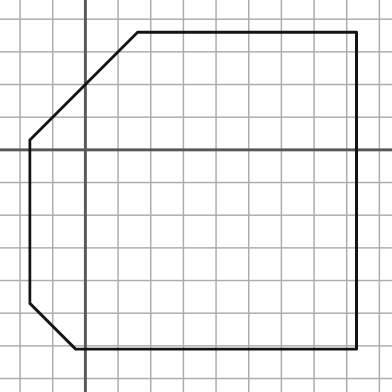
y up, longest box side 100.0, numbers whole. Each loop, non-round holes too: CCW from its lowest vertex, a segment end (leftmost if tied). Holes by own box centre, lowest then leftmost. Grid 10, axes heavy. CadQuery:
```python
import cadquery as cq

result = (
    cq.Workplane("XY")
    .moveTo(-3.0, -61.0)
    .lineTo(83.0, -61.0)
    .lineTo(83.0, 36.0)
    .lineTo(16.0, 36.0)
    .lineTo(-17.0, 3.0)
    .lineTo(-17.0, -47.0)
    .close()
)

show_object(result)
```